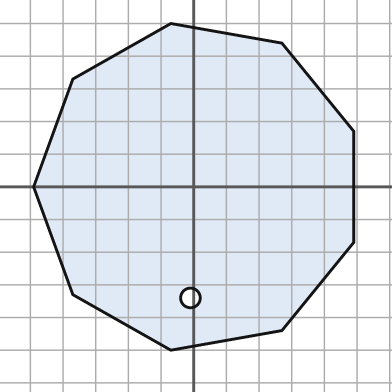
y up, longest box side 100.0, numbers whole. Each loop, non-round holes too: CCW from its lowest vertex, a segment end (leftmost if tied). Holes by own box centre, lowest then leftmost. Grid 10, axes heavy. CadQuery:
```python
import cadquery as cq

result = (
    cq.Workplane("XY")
    .moveTo(-7.0, -50.0)
    .lineTo(27.0, -44.0)
    .lineTo(49.0, -17.0)
    .lineTo(49.0, 17.0)
    .lineTo(27.0, 44.0)
    .lineTo(-7.0, 50.0)
    .lineTo(-37.0, 33.0)
    .lineTo(-49.0, 0.0)
    .lineTo(-37.0, -33.0)
    .close()
    .moveTo(-1.0, -34.0)
    .circle(3.0)
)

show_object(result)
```